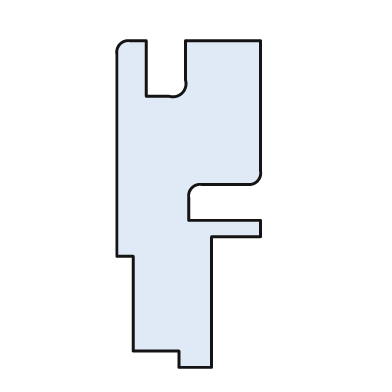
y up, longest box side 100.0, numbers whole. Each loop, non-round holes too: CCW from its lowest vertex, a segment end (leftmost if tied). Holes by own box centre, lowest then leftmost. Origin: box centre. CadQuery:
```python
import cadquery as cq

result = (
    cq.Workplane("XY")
    .moveTo(-3.0, -50.0)
    .lineTo(7.0, -50.0)
    .lineTo(7.0, -10.0)
    .lineTo(22.0, -10.0)
    .lineTo(22.0, -5.0)
    .lineTo(0.0, -5.0)
    .lineTo(0.0, 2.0)
    .threePointArc((1.0, 5.0), (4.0, 6.0))
    .lineTo(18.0, 6.0)
    .threePointArc((21.0, 7.0), (22.0, 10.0))
    .lineTo(22.0, 50.0)
    .lineTo(-1.0, 50.0)
    .lineTo(-1.0, 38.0)
    .threePointArc((-2.0, 34.0), (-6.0, 33.0))
    .lineTo(-13.0, 33.0)
    .lineTo(-13.0, 50.0)
    .lineTo(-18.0, 50.0)
    .threePointArc((-21.0, 49.0), (-22.0, 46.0))
    .lineTo(-22.0, -16.0)
    .lineTo(-17.0, -16.0)
    .lineTo(-17.0, -45.0)
    .lineTo(-3.0, -45.0)
    .close()
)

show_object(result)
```